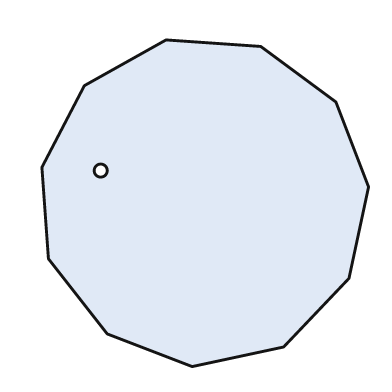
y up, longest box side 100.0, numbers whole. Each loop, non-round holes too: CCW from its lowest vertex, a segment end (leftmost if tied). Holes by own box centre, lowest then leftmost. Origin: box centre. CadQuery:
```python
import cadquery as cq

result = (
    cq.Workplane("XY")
    .moveTo(-4.0, -50.0)
    .lineTo(24.0, -44.0)
    .lineTo(44.0, -23.0)
    .lineTo(50.0, 5.0)
    .lineTo(40.0, 31.0)
    .lineTo(17.0, 48.0)
    .lineTo(-12.0, 50.0)
    .lineTo(-37.0, 36.0)
    .lineTo(-50.0, 11.0)
    .lineTo(-48.0, -17.0)
    .lineTo(-30.0, -40.0)
    .close()
    .moveTo(-32.0, 10.0)
    .circle(2.0)
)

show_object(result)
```